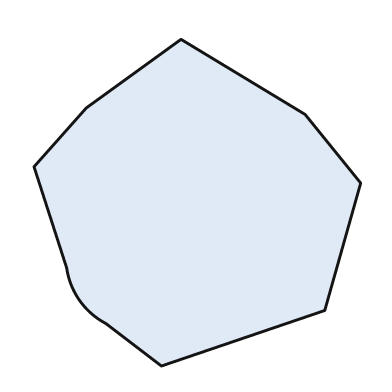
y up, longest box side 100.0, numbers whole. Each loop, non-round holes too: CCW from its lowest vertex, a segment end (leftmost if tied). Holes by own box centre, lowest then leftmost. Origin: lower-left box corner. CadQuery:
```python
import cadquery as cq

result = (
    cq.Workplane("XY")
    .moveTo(39.0, 0.0)
    .lineTo(89.0, 17.0)
    .lineTo(100.0, 56.0)
    .lineTo(83.0, 77.0)
    .lineTo(45.0, 100.0)
    .lineTo(16.0, 79.0)
    .lineTo(0.0, 61.0)
    .lineTo(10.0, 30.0)
    .threePointArc((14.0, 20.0), (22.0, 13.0))
    .close()
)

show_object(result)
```